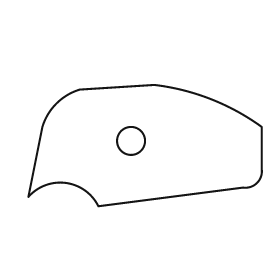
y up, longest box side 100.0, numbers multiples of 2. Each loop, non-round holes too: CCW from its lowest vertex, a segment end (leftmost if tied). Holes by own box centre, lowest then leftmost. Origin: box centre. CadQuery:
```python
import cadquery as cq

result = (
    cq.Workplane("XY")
    .moveTo(-20.0, -26.0)
    .lineTo(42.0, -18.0)
    .threePointArc((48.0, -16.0), (50.0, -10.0))
    .lineTo(50.0, 8.0)
    .threePointArc((28.0, 20.0), (4.0, 26.0))
    .lineTo(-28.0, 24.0)
    .threePointArc((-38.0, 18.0), (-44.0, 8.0))
    .lineTo(-50.0, -22.0)
    .threePointArc((-34.0, -16.0), (-20.0, -26.0))
    .close()
    .moveTo(-6.0, 2.0)
    .circle(6.0)
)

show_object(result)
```